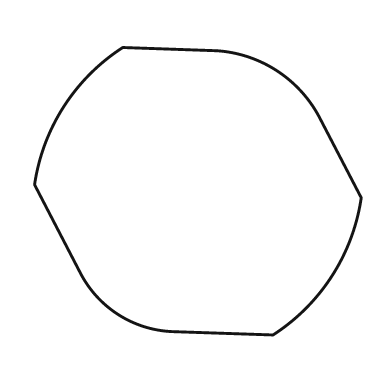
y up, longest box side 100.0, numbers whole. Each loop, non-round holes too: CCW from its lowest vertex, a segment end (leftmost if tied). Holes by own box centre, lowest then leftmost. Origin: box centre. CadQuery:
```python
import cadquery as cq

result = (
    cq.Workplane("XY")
    .moveTo(23.0, -44.0)
    .threePointArc((41.0, -26.0), (50.0, -2.0))
    .lineTo(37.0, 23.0)
    .threePointArc((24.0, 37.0), (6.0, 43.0))
    .lineTo(-23.0, 44.0)
    .threePointArc((-41.0, 26.0), (-50.0, 2.0))
    .lineTo(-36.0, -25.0)
    .threePointArc((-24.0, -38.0), (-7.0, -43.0))
    .close()
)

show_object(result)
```